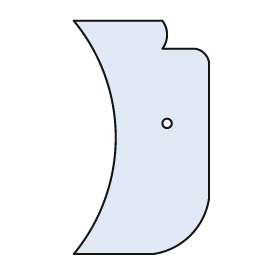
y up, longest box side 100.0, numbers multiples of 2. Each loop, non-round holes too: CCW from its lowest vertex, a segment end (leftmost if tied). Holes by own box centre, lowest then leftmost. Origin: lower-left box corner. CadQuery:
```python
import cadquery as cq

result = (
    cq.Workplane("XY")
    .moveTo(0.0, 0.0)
    .lineTo(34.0, 0.0)
    .threePointArc((50.0, 8.0), (58.0, 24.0))
    .lineTo(58.0, 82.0)
    .threePointArc((56.0, 86.0), (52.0, 88.0))
    .lineTo(38.0, 88.0)
    .threePointArc((40.0, 94.0), (38.0, 100.0))
    .lineTo(0.0, 100.0)
    .threePointArc((18.0, 50.0), (0.0, 0.0))
    .close()
    .moveTo(40.0, 56.0)
    .circle(2.0)
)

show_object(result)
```